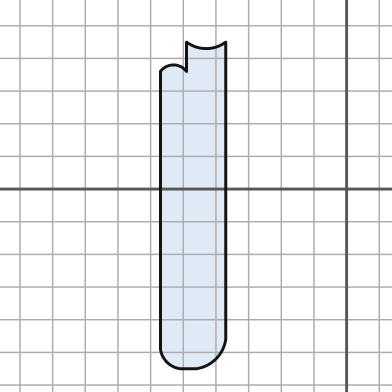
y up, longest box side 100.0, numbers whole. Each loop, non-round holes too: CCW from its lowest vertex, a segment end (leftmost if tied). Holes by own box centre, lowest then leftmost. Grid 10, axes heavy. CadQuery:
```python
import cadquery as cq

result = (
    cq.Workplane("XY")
    .moveTo(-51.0, -55.0)
    .lineTo(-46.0, -55.0)
    .threePointArc((-40.0, -52.0), (-37.0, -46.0))
    .lineTo(-37.0, 45.0)
    .threePointArc((-43.0, 43.0), (-49.0, 45.0))
    .lineTo(-49.0, 36.0)
    .threePointArc((-53.0, 38.0), (-57.0, 36.0))
    .lineTo(-57.0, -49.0)
    .threePointArc((-55.0, -53.0), (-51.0, -55.0))
    .close()
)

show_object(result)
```